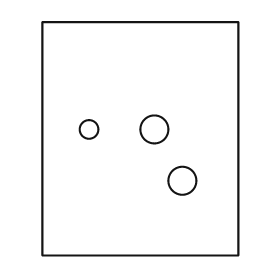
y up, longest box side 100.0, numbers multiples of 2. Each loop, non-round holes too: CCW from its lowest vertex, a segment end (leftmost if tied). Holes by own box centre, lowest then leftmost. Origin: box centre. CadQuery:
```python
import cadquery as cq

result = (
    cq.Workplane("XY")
    .moveTo(-42.0, -50.0)
    .lineTo(42.0, -50.0)
    .lineTo(42.0, 50.0)
    .lineTo(-42.0, 50.0)
    .close()
    .moveTo(18.0, -18.0)
    .circle(6.0)
    .moveTo(-22.0, 4.0)
    .circle(4.0)
    .moveTo(6.0, 4.0)
    .circle(6.0)
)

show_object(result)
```